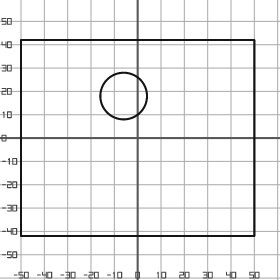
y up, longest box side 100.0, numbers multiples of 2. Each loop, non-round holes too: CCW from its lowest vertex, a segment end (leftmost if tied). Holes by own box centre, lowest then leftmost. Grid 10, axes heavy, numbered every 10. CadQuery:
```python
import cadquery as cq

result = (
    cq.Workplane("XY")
    .moveTo(-50.0, -42.0)
    .lineTo(50.0, -42.0)
    .lineTo(50.0, 42.0)
    .lineTo(-50.0, 42.0)
    .close()
    .moveTo(-6.0, 18.0)
    .circle(10.0)
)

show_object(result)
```